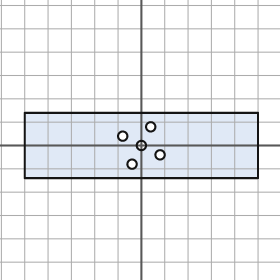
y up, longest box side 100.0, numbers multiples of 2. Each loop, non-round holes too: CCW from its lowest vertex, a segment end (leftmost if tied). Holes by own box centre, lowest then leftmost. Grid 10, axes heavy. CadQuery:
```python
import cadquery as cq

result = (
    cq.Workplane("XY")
    .moveTo(-50.0, -14.0)
    .lineTo(50.0, -14.0)
    .lineTo(50.0, 14.0)
    .lineTo(-50.0, 14.0)
    .close()
    .moveTo(-4.0, -8.0)
    .circle(2.0)
    .moveTo(8.0, -4.0)
    .circle(2.0)
    .moveTo(0.0, 0.0)
    .circle(2.0)
    .moveTo(-8.0, 4.0)
    .circle(2.0)
    .moveTo(4.0, 8.0)
    .circle(2.0)
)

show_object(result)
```